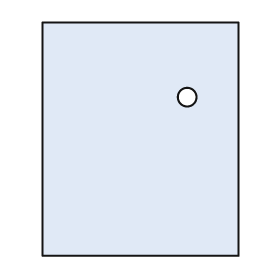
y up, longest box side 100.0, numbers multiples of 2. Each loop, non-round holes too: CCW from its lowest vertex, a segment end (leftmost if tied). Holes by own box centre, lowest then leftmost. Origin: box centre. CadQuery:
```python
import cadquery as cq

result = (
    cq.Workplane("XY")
    .moveTo(-42.0, -50.0)
    .lineTo(42.0, -50.0)
    .lineTo(42.0, 50.0)
    .lineTo(-42.0, 50.0)
    .close()
    .moveTo(20.0, 18.0)
    .circle(4.0)
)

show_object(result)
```